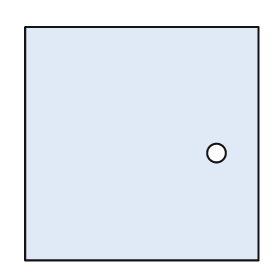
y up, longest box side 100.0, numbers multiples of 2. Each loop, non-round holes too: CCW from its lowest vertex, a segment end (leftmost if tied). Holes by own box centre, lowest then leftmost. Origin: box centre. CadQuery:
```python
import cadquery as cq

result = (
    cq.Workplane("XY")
    .moveTo(-50.0, -50.0)
    .lineTo(50.0, -50.0)
    .lineTo(50.0, 50.0)
    .lineTo(-50.0, 50.0)
    .close()
    .moveTo(32.0, -4.0)
    .circle(4.0)
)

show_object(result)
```